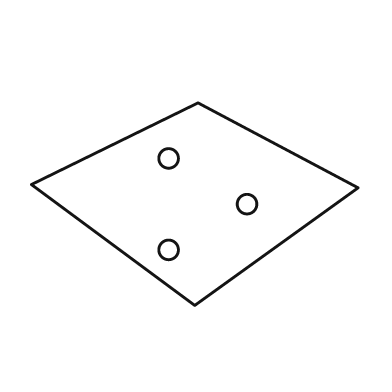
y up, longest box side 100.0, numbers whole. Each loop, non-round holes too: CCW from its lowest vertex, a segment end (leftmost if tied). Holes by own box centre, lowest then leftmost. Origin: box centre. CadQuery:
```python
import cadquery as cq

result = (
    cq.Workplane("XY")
    .moveTo(0.0, -31.0)
    .lineTo(50.0, 5.0)
    .lineTo(1.0, 31.0)
    .lineTo(-50.0, 6.0)
    .close()
    .moveTo(-8.0, -14.0)
    .circle(3.0)
    .moveTo(16.0, 0.0)
    .circle(3.0)
    .moveTo(-8.0, 14.0)
    .circle(3.0)
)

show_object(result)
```